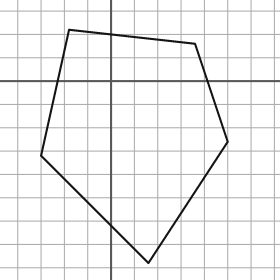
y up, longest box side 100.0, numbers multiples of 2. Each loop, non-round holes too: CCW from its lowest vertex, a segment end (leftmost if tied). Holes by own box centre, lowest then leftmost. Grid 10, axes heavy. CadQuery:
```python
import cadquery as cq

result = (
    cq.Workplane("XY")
    .moveTo(16.0, -78.0)
    .lineTo(50.0, -26.0)
    .lineTo(36.0, 16.0)
    .lineTo(-18.0, 22.0)
    .lineTo(-30.0, -32.0)
    .close()
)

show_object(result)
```